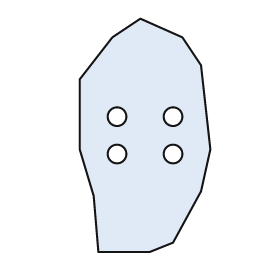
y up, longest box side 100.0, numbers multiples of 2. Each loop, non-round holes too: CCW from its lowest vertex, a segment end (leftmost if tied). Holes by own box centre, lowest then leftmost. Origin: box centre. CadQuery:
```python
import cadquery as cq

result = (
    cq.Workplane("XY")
    .moveTo(-20.0, -50.0)
    .lineTo(2.0, -50.0)
    .lineTo(12.0, -46.0)
    .lineTo(24.0, -24.0)
    .lineTo(28.0, -6.0)
    .lineTo(24.0, 30.0)
    .lineTo(16.0, 42.0)
    .lineTo(-2.0, 50.0)
    .lineTo(-14.0, 42.0)
    .lineTo(-28.0, 24.0)
    .lineTo(-28.0, -6.0)
    .lineTo(-22.0, -26.0)
    .close()
    .moveTo(-12.0, -8.0)
    .circle(4.0)
    .moveTo(12.0, -8.0)
    .circle(4.0)
    .moveTo(-12.0, 8.0)
    .circle(4.0)
    .moveTo(12.0, 8.0)
    .circle(4.0)
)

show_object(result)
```